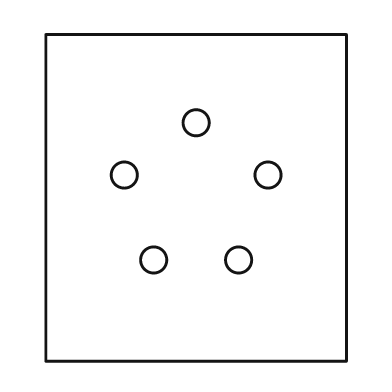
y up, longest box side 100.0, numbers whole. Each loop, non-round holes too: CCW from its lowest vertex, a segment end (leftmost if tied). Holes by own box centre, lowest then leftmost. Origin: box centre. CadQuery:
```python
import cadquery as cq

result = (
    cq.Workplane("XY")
    .moveTo(-46.0, -50.0)
    .lineTo(46.0, -50.0)
    .lineTo(46.0, 50.0)
    .lineTo(-46.0, 50.0)
    .close()
    .moveTo(-13.0, -19.0)
    .circle(4.0)
    .moveTo(13.0, -19.0)
    .circle(4.0)
    .moveTo(-22.0, 7.0)
    .circle(4.0)
    .moveTo(22.0, 7.0)
    .circle(4.0)
    .moveTo(0.0, 23.0)
    .circle(4.0)
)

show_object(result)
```